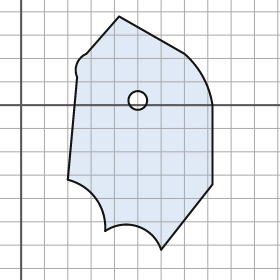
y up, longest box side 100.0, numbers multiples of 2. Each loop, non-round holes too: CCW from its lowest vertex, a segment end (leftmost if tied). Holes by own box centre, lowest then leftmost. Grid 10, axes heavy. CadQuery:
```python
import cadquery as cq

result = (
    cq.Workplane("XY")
    .moveTo(60.0, -62.0)
    .lineTo(82.0, -34.0)
    .lineTo(82.0, 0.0)
    .threePointArc((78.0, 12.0), (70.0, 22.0))
    .lineTo(42.0, 38.0)
    .lineTo(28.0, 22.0)
    .threePointArc((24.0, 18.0), (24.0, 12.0))
    .lineTo(20.0, -32.0)
    .threePointArc((32.0, -40.0), (36.0, -54.0))
    .threePointArc((50.0, -52.0), (60.0, -62.0))
    .close()
    .moveTo(50.0, 2.0)
    .circle(4.0)
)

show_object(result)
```